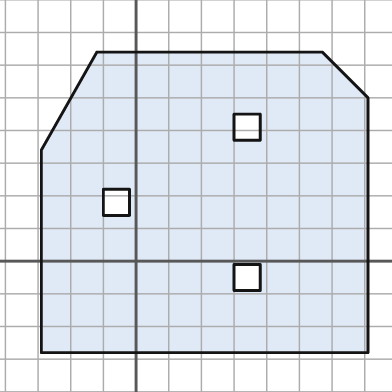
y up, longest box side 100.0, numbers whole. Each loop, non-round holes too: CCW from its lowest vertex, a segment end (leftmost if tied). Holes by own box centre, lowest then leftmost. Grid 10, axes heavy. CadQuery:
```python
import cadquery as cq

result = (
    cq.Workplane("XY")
    .moveTo(-29.0, -28.0)
    .lineTo(71.0, -28.0)
    .lineTo(71.0, 50.0)
    .lineTo(57.0, 64.0)
    .lineTo(-12.0, 64.0)
    .lineTo(-29.0, 34.0)
    .close()
    .moveTo(30.0, -9.0)
    .lineTo(38.0, -9.0)
    .lineTo(38.0, -1.0)
    .lineTo(30.0, -1.0)
    .close()
    .moveTo(-10.0, 14.0)
    .lineTo(-2.0, 14.0)
    .lineTo(-2.0, 22.0)
    .lineTo(-10.0, 22.0)
    .close()
    .moveTo(30.0, 37.0)
    .lineTo(38.0, 37.0)
    .lineTo(38.0, 45.0)
    .lineTo(30.0, 45.0)
    .close()
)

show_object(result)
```